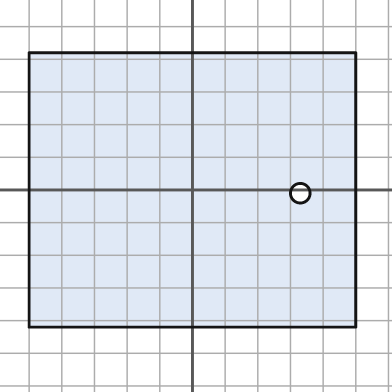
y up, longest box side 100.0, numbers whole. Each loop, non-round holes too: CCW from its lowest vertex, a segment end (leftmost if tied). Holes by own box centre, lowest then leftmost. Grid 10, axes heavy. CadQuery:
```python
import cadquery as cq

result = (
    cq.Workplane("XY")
    .moveTo(-50.0, -42.0)
    .lineTo(50.0, -42.0)
    .lineTo(50.0, 42.0)
    .lineTo(-50.0, 42.0)
    .close()
    .moveTo(33.0, -1.0)
    .circle(3.0)
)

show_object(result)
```